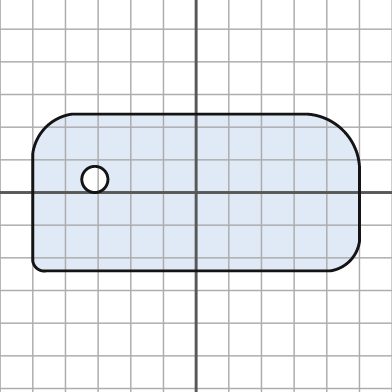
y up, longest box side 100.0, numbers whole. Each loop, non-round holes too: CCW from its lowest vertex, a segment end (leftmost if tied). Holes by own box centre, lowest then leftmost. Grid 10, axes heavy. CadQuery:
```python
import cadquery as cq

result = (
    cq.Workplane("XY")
    .moveTo(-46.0, -24.0)
    .lineTo(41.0, -24.0)
    .threePointArc((47.0, -21.0), (50.0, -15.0))
    .lineTo(50.0, 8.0)
    .threePointArc((45.0, 19.0), (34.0, 24.0))
    .lineTo(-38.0, 24.0)
    .threePointArc((-46.0, 20.0), (-50.0, 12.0))
    .lineTo(-50.0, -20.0)
    .threePointArc((-49.0, -23.0), (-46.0, -24.0))
    .close()
    .moveTo(-31.0, 4.0)
    .circle(4.0)
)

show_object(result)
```